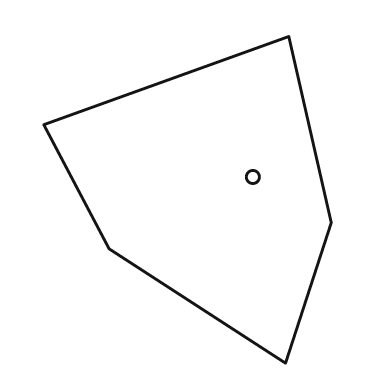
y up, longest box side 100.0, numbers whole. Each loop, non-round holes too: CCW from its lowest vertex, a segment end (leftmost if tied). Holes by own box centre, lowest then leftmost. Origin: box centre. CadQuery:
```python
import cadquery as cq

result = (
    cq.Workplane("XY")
    .moveTo(30.0, -50.0)
    .lineTo(44.0, -7.0)
    .lineTo(31.0, 50.0)
    .lineTo(-44.0, 23.0)
    .lineTo(-24.0, -15.0)
    .close()
    .moveTo(20.0, 7.0)
    .circle(2.0)
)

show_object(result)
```